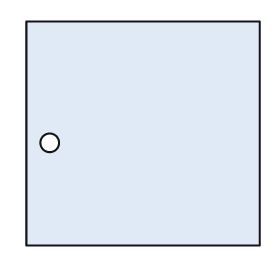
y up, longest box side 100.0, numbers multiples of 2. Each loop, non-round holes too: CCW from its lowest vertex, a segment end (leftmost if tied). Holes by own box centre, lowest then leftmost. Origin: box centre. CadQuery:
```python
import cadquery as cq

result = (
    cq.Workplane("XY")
    .moveTo(-50.0, -48.0)
    .lineTo(50.0, -48.0)
    .lineTo(50.0, 48.0)
    .lineTo(-50.0, 48.0)
    .close()
    .moveTo(-40.0, -4.0)
    .circle(4.0)
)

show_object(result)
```